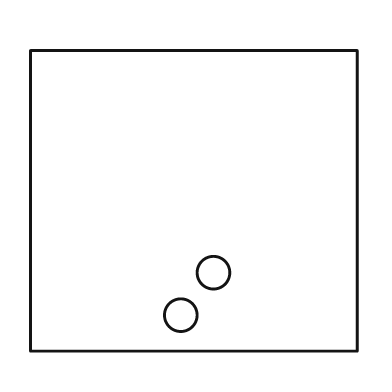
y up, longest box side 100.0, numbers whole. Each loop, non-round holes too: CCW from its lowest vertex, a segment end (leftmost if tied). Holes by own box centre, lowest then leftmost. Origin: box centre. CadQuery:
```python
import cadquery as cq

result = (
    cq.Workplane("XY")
    .moveTo(-50.0, -46.0)
    .lineTo(50.0, -46.0)
    .lineTo(50.0, 46.0)
    .lineTo(-50.0, 46.0)
    .close()
    .moveTo(-4.0, -35.0)
    .circle(5.0)
    .moveTo(6.0, -22.0)
    .circle(5.0)
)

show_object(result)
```